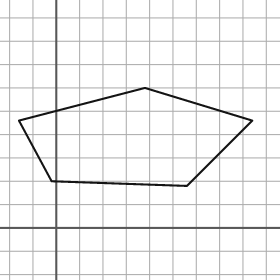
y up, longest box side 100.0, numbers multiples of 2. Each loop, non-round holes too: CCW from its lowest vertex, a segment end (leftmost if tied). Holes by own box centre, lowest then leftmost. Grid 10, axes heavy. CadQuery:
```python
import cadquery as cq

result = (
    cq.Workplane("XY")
    .moveTo(56.0, 18.0)
    .lineTo(84.0, 46.0)
    .lineTo(38.0, 60.0)
    .lineTo(-16.0, 46.0)
    .lineTo(-2.0, 20.0)
    .close()
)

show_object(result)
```